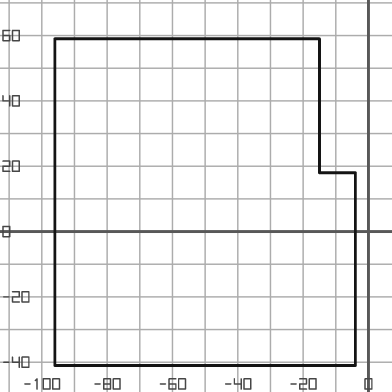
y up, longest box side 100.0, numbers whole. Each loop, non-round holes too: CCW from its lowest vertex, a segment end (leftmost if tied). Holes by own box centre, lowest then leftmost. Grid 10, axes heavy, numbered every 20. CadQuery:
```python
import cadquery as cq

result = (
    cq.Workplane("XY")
    .moveTo(-96.0, -41.0)
    .lineTo(-4.0, -41.0)
    .lineTo(-4.0, 18.0)
    .lineTo(-15.0, 18.0)
    .lineTo(-15.0, 59.0)
    .lineTo(-96.0, 59.0)
    .close()
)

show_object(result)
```